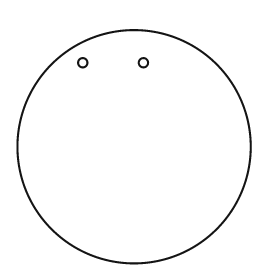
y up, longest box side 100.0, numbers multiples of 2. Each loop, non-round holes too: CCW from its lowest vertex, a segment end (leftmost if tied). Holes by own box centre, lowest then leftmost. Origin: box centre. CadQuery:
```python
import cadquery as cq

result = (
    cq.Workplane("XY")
    .moveTo(0.0, 0.0)
    .circle(50.0)
    .moveTo(-22.0, 36.0)
    .circle(2.0)
    .moveTo(4.0, 36.0)
    .circle(2.0)
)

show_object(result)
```